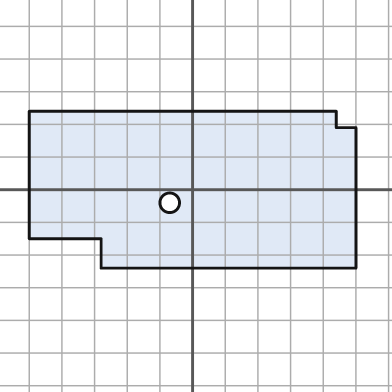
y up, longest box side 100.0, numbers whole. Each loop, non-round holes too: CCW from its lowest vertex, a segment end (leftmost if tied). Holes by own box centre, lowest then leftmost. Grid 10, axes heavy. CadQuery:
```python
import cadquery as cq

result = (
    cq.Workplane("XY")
    .moveTo(-28.0, -24.0)
    .lineTo(50.0, -24.0)
    .lineTo(50.0, 19.0)
    .lineTo(44.0, 19.0)
    .lineTo(44.0, 24.0)
    .lineTo(-50.0, 24.0)
    .lineTo(-50.0, -15.0)
    .lineTo(-28.0, -15.0)
    .close()
    .moveTo(-7.0, -4.0)
    .circle(3.0)
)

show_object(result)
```